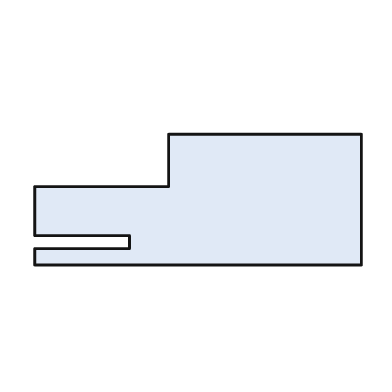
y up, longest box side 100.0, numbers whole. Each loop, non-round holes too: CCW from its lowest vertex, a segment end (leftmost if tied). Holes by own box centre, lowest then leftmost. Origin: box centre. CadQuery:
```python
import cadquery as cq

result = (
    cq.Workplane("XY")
    .moveTo(-50.0, -20.0)
    .lineTo(50.0, -20.0)
    .lineTo(50.0, 20.0)
    .lineTo(-9.0, 20.0)
    .lineTo(-9.0, 4.0)
    .lineTo(-50.0, 4.0)
    .lineTo(-50.0, -11.0)
    .lineTo(-21.0, -11.0)
    .lineTo(-21.0, -15.0)
    .lineTo(-50.0, -15.0)
    .close()
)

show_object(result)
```